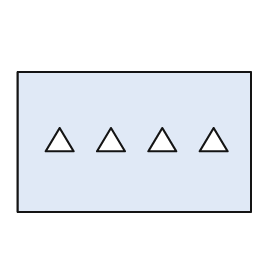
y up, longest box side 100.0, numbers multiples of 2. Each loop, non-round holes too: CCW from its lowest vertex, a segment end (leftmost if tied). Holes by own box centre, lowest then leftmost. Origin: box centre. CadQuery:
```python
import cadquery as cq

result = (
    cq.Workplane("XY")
    .moveTo(-50.0, -30.0)
    .lineTo(50.0, -30.0)
    .lineTo(50.0, 30.0)
    .lineTo(-50.0, 30.0)
    .close()
    .moveTo(-38.0, -4.0)
    .lineTo(-26.0, -4.0)
    .lineTo(-32.0, 6.0)
    .close()
    .moveTo(-16.0, -4.0)
    .lineTo(-4.0, -4.0)
    .lineTo(-10.0, 6.0)
    .close()
    .moveTo(6.0, -4.0)
    .lineTo(18.0, -4.0)
    .lineTo(12.0, 6.0)
    .close()
    .moveTo(28.0, -4.0)
    .lineTo(40.0, -4.0)
    .lineTo(34.0, 6.0)
    .close()
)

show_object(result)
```